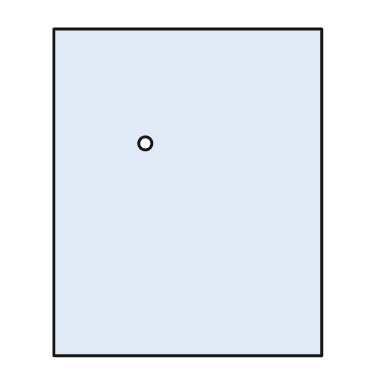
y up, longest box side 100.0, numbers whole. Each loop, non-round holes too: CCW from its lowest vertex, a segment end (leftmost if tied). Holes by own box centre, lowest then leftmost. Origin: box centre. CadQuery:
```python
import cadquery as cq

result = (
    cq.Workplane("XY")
    .moveTo(-41.0, -50.0)
    .lineTo(41.0, -50.0)
    .lineTo(41.0, 50.0)
    .lineTo(-41.0, 50.0)
    .close()
    .moveTo(-13.0, 15.0)
    .circle(2.0)
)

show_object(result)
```